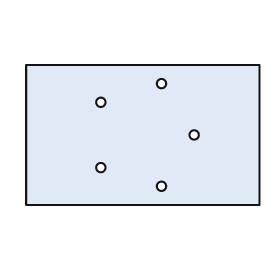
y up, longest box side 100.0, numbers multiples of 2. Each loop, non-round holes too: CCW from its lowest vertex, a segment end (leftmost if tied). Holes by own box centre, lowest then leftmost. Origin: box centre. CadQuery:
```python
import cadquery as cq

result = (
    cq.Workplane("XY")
    .moveTo(-50.0, -30.0)
    .lineTo(50.0, -30.0)
    .lineTo(50.0, 30.0)
    .lineTo(-50.0, 30.0)
    .close()
    .moveTo(8.0, -22.0)
    .circle(2.0)
    .moveTo(-18.0, -14.0)
    .circle(2.0)
    .moveTo(22.0, 0.0)
    .circle(2.0)
    .moveTo(-18.0, 14.0)
    .circle(2.0)
    .moveTo(8.0, 22.0)
    .circle(2.0)
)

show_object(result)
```